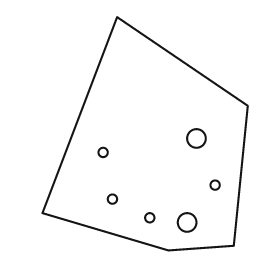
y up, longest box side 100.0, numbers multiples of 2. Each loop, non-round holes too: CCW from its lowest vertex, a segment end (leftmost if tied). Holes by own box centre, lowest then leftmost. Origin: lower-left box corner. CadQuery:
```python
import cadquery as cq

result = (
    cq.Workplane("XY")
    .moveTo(54.0, 0.0)
    .lineTo(82.0, 2.0)
    .lineTo(88.0, 62.0)
    .lineTo(32.0, 100.0)
    .lineTo(0.0, 16.0)
    .close()
    .moveTo(62.0, 12.0)
    .circle(4.0)
    .moveTo(46.0, 14.0)
    .circle(2.0)
    .moveTo(30.0, 22.0)
    .circle(2.0)
    .moveTo(74.0, 28.0)
    .circle(2.0)
    .moveTo(26.0, 42.0)
    .circle(2.0)
    .moveTo(66.0, 48.0)
    .circle(4.0)
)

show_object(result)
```